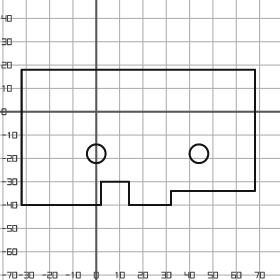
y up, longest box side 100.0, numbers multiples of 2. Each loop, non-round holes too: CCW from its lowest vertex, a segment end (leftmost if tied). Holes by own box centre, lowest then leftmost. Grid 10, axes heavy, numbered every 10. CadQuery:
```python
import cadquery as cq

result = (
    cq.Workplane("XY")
    .moveTo(-32.0, -40.0)
    .lineTo(2.0, -40.0)
    .lineTo(2.0, -30.0)
    .lineTo(14.0, -30.0)
    .lineTo(14.0, -40.0)
    .lineTo(32.0, -40.0)
    .lineTo(32.0, -34.0)
    .lineTo(68.0, -34.0)
    .lineTo(68.0, 18.0)
    .lineTo(-32.0, 18.0)
    .close()
    .moveTo(0.0, -18.0)
    .circle(4.0)
    .moveTo(44.0, -18.0)
    .circle(4.0)
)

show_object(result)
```